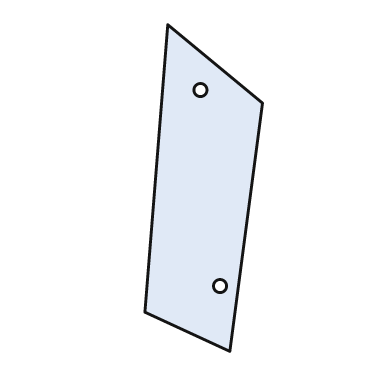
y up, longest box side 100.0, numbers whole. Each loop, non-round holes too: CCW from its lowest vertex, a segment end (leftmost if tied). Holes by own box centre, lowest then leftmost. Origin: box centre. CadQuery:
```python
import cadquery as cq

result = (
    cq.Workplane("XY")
    .moveTo(8.0, -50.0)
    .lineTo(18.0, 26.0)
    .lineTo(-11.0, 50.0)
    .lineTo(-18.0, -38.0)
    .close()
    .moveTo(5.0, -30.0)
    .circle(2.0)
    .moveTo(-1.0, 30.0)
    .circle(2.0)
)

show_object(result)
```